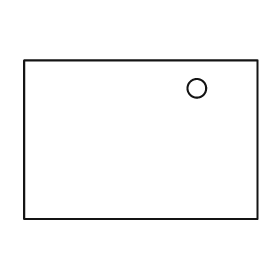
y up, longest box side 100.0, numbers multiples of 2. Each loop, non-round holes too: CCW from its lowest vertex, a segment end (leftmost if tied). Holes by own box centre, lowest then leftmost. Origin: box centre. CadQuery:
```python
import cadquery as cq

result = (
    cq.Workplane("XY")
    .moveTo(-50.0, -34.0)
    .lineTo(50.0, -34.0)
    .lineTo(50.0, 34.0)
    .lineTo(-50.0, 34.0)
    .close()
    .moveTo(24.0, 22.0)
    .circle(4.0)
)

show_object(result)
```